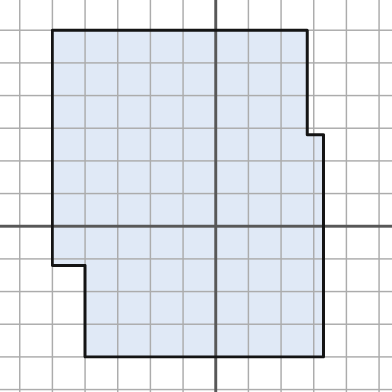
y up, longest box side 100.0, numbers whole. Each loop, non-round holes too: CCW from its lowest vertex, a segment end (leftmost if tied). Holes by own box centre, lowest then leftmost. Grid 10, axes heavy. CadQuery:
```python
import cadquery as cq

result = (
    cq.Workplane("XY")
    .moveTo(-40.0, -40.0)
    .lineTo(33.0, -40.0)
    .lineTo(33.0, 28.0)
    .lineTo(28.0, 28.0)
    .lineTo(28.0, 60.0)
    .lineTo(-50.0, 60.0)
    .lineTo(-50.0, -12.0)
    .lineTo(-40.0, -12.0)
    .close()
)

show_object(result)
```